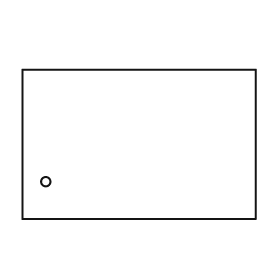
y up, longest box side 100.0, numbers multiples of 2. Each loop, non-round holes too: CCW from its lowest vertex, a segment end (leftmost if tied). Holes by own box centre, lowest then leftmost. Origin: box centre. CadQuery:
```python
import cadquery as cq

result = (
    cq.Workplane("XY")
    .moveTo(-50.0, -32.0)
    .lineTo(50.0, -32.0)
    .lineTo(50.0, 32.0)
    .lineTo(-50.0, 32.0)
    .close()
    .moveTo(-40.0, -16.0)
    .circle(2.0)
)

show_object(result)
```